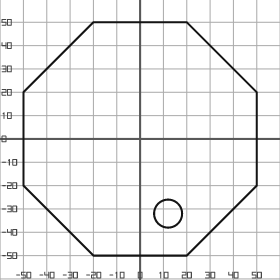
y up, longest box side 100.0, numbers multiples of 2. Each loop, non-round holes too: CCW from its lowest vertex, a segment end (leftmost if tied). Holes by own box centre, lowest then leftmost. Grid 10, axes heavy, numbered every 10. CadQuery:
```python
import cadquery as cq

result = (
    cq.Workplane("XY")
    .moveTo(-20.0, -50.0)
    .lineTo(20.0, -50.0)
    .lineTo(50.0, -20.0)
    .lineTo(50.0, 20.0)
    .lineTo(20.0, 50.0)
    .lineTo(-20.0, 50.0)
    .lineTo(-50.0, 20.0)
    .lineTo(-50.0, -20.0)
    .close()
    .moveTo(12.0, -32.0)
    .circle(6.0)
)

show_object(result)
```